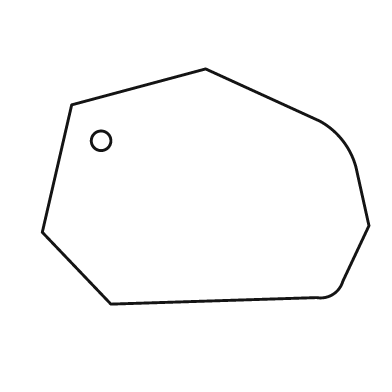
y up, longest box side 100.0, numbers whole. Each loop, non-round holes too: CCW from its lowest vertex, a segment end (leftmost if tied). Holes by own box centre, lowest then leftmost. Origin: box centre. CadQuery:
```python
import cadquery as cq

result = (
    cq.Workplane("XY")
    .moveTo(-29.0, -36.0)
    .lineTo(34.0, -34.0)
    .threePointArc((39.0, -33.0), (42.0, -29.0))
    .lineTo(50.0, -12.0)
    .lineTo(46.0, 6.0)
    .threePointArc((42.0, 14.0), (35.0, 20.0))
    .lineTo(0.0, 36.0)
    .lineTo(-41.0, 25.0)
    .lineTo(-50.0, -14.0)
    .close()
    .moveTo(-32.0, 14.0)
    .circle(3.0)
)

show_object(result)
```